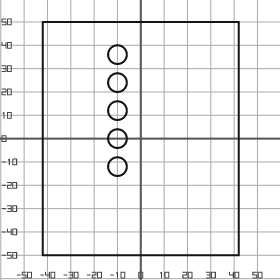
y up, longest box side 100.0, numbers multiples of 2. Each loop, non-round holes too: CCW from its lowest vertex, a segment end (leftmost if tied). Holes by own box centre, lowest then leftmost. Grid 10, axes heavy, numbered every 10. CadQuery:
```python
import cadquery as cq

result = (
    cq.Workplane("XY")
    .moveTo(-42.0, -50.0)
    .lineTo(42.0, -50.0)
    .lineTo(42.0, 50.0)
    .lineTo(-42.0, 50.0)
    .close()
    .moveTo(-10.0, -12.0)
    .circle(4.0)
    .moveTo(-10.0, 0.0)
    .circle(4.0)
    .moveTo(-10.0, 12.0)
    .circle(4.0)
    .moveTo(-10.0, 24.0)
    .circle(4.0)
    .moveTo(-10.0, 36.0)
    .circle(4.0)
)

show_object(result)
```